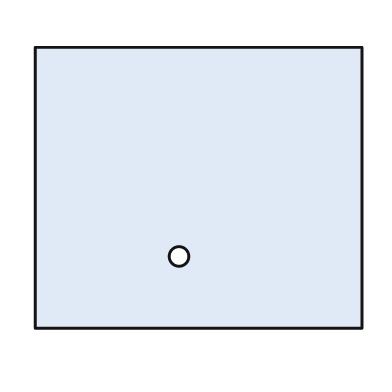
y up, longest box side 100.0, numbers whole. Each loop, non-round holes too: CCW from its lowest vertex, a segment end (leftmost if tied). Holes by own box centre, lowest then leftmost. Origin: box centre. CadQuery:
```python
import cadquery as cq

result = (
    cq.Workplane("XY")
    .moveTo(-50.0, -43.0)
    .lineTo(50.0, -43.0)
    .lineTo(50.0, 43.0)
    .lineTo(-50.0, 43.0)
    .close()
    .moveTo(-6.0, -21.0)
    .circle(3.0)
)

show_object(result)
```